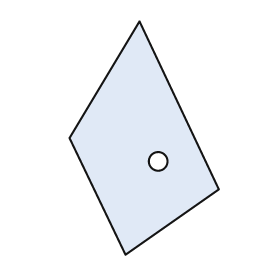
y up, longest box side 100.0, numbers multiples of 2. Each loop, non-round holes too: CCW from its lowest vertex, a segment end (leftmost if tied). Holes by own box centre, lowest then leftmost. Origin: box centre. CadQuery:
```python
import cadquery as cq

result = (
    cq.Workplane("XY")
    .moveTo(-8.0, -50.0)
    .lineTo(32.0, -22.0)
    .lineTo(-2.0, 50.0)
    .lineTo(-32.0, 0.0)
    .close()
    .moveTo(6.0, -10.0)
    .circle(4.0)
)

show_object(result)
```